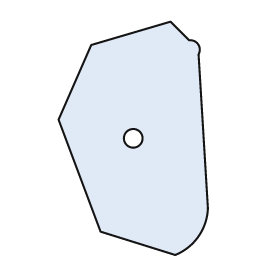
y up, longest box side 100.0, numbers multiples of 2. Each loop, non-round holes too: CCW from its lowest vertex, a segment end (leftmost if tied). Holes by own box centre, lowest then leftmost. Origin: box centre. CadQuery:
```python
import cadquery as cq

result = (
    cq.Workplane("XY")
    .moveTo(18.0, -50.0)
    .threePointArc((28.0, -42.0), (32.0, -30.0))
    .lineTo(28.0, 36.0)
    .threePointArc((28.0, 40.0), (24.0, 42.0))
    .lineTo(16.0, 50.0)
    .lineTo(-18.0, 40.0)
    .lineTo(-32.0, 8.0)
    .lineTo(-14.0, -40.0)
    .close()
    .moveTo(0.0, 0.0)
    .circle(4.0)
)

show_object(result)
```